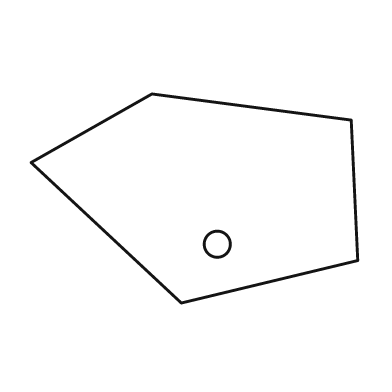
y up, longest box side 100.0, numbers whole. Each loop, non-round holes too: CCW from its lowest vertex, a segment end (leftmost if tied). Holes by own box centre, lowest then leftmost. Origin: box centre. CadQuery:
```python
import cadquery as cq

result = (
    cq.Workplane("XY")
    .moveTo(-4.0, -32.0)
    .lineTo(50.0, -19.0)
    .lineTo(48.0, 24.0)
    .lineTo(-13.0, 32.0)
    .lineTo(-50.0, 11.0)
    .close()
    .moveTo(7.0, -14.0)
    .circle(4.0)
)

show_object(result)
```